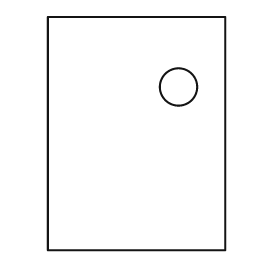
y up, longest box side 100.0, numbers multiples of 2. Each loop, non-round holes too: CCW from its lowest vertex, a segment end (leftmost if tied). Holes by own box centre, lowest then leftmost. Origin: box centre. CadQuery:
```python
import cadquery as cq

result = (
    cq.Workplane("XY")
    .moveTo(-38.0, -50.0)
    .lineTo(38.0, -50.0)
    .lineTo(38.0, 50.0)
    .lineTo(-38.0, 50.0)
    .close()
    .moveTo(18.0, 20.0)
    .circle(8.0)
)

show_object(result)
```